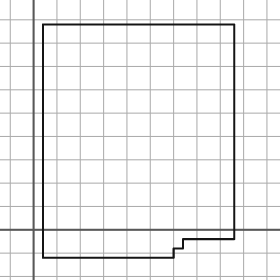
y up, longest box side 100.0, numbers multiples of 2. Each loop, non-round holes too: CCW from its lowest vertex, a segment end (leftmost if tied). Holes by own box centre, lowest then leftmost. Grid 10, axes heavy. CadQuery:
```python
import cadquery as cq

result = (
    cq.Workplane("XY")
    .moveTo(4.0, -12.0)
    .lineTo(60.0, -12.0)
    .lineTo(60.0, -8.0)
    .lineTo(64.0, -8.0)
    .lineTo(64.0, -4.0)
    .lineTo(86.0, -4.0)
    .lineTo(86.0, 88.0)
    .lineTo(4.0, 88.0)
    .close()
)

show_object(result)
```